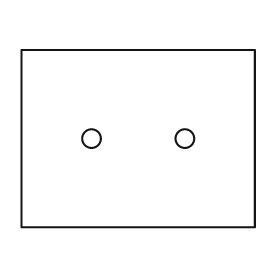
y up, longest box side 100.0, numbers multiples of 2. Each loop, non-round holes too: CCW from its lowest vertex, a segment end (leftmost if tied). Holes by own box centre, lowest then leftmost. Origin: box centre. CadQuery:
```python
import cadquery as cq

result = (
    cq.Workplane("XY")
    .moveTo(-50.0, -38.0)
    .lineTo(50.0, -38.0)
    .lineTo(50.0, 38.0)
    .lineTo(-50.0, 38.0)
    .close()
    .moveTo(-20.0, 0.0)
    .circle(4.0)
    .moveTo(20.0, 0.0)
    .circle(4.0)
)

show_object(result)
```